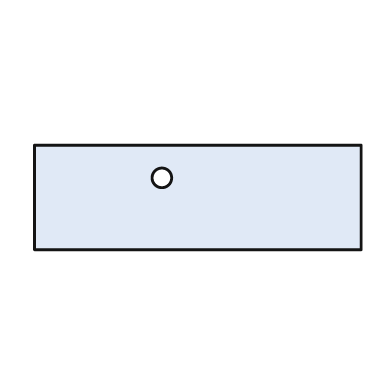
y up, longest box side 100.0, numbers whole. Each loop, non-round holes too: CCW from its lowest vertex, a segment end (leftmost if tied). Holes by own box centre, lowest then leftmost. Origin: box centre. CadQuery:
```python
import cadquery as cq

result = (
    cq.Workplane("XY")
    .moveTo(-50.0, -16.0)
    .lineTo(50.0, -16.0)
    .lineTo(50.0, 16.0)
    .lineTo(-50.0, 16.0)
    .close()
    .moveTo(-11.0, 6.0)
    .circle(3.0)
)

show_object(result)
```